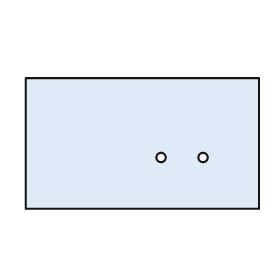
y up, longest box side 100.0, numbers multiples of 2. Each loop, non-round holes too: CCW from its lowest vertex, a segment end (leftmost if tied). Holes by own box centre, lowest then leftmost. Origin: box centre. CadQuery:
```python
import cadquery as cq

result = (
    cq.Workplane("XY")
    .moveTo(-50.0, -28.0)
    .lineTo(50.0, -28.0)
    .lineTo(50.0, 28.0)
    .lineTo(-50.0, 28.0)
    .close()
    .moveTo(8.0, -6.0)
    .circle(2.0)
    .moveTo(26.0, -6.0)
    .circle(2.0)
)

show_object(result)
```